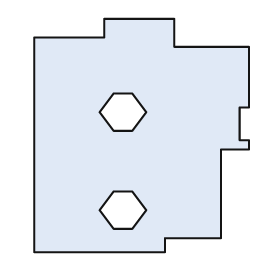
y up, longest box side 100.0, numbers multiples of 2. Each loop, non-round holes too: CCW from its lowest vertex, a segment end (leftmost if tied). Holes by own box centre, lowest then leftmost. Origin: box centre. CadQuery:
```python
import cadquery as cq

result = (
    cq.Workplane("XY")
    .moveTo(-46.0, -50.0)
    .lineTo(10.0, -50.0)
    .lineTo(10.0, -44.0)
    .lineTo(34.0, -44.0)
    .lineTo(34.0, -6.0)
    .lineTo(46.0, -6.0)
    .lineTo(46.0, -2.0)
    .lineTo(42.0, -2.0)
    .lineTo(42.0, 12.0)
    .lineTo(46.0, 12.0)
    .lineTo(46.0, 38.0)
    .lineTo(14.0, 38.0)
    .lineTo(14.0, 50.0)
    .lineTo(-16.0, 50.0)
    .lineTo(-16.0, 42.0)
    .lineTo(-46.0, 42.0)
    .close()
    .moveTo(-12.0, -40.0)
    .lineTo(-4.0, -40.0)
    .lineTo(2.0, -32.0)
    .lineTo(-4.0, -24.0)
    .lineTo(-12.0, -24.0)
    .lineTo(-18.0, -32.0)
    .close()
    .moveTo(-12.0, 2.0)
    .lineTo(-4.0, 2.0)
    .lineTo(2.0, 10.0)
    .lineTo(-4.0, 18.0)
    .lineTo(-12.0, 18.0)
    .lineTo(-18.0, 10.0)
    .close()
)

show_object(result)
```